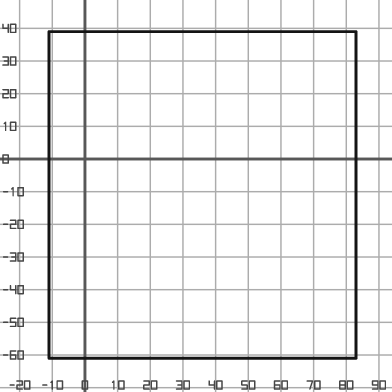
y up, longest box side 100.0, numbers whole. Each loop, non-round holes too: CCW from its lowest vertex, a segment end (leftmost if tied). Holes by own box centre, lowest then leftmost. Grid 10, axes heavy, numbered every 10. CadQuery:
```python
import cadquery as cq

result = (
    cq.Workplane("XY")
    .moveTo(-11.0, -61.0)
    .lineTo(83.0, -61.0)
    .lineTo(83.0, 39.0)
    .lineTo(-11.0, 39.0)
    .close()
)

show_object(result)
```